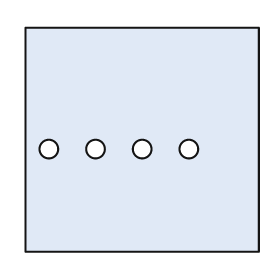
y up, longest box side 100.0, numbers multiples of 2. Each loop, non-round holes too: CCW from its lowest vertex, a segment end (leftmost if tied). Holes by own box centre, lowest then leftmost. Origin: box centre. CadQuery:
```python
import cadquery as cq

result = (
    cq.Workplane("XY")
    .moveTo(-50.0, -48.0)
    .lineTo(50.0, -48.0)
    .lineTo(50.0, 48.0)
    .lineTo(-50.0, 48.0)
    .close()
    .moveTo(-40.0, -4.0)
    .circle(4.0)
    .moveTo(-20.0, -4.0)
    .circle(4.0)
    .moveTo(0.0, -4.0)
    .circle(4.0)
    .moveTo(20.0, -4.0)
    .circle(4.0)
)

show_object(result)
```